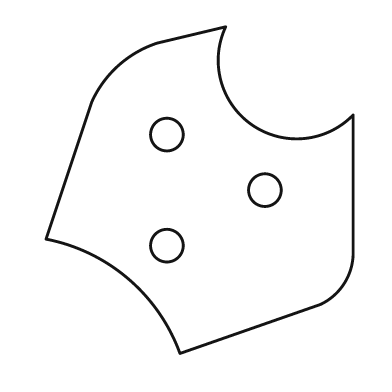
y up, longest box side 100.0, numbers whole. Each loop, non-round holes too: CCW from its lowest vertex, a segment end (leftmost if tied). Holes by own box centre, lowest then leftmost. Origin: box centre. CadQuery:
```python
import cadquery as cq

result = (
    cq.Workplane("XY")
    .moveTo(-6.0, -50.0)
    .lineTo(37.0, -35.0)
    .threePointArc((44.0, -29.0), (47.0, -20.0))
    .lineTo(47.0, 23.0)
    .threePointArc((16.0, 20.0), (8.0, 50.0))
    .lineTo(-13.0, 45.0)
    .threePointArc((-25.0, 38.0), (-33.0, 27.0))
    .lineTo(-47.0, -15.0)
    .threePointArc((-22.0, -27.0), (-6.0, -50.0))
    .close()
    .moveTo(-10.0, -17.0)
    .circle(5.0)
    .moveTo(20.0, 0.0)
    .circle(5.0)
    .moveTo(-10.0, 17.0)
    .circle(5.0)
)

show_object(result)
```